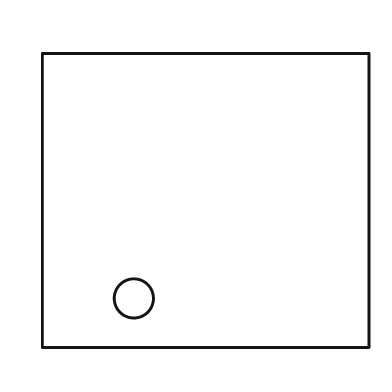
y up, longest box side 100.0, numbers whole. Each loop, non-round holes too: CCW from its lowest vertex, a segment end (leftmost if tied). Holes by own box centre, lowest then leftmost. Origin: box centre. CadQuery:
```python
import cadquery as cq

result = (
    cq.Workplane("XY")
    .moveTo(-50.0, -45.0)
    .lineTo(50.0, -45.0)
    .lineTo(50.0, 45.0)
    .lineTo(-50.0, 45.0)
    .close()
    .moveTo(-22.0, -30.0)
    .circle(6.0)
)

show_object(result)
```